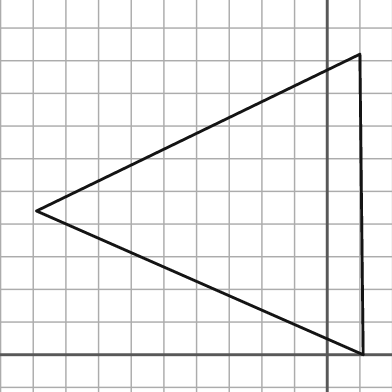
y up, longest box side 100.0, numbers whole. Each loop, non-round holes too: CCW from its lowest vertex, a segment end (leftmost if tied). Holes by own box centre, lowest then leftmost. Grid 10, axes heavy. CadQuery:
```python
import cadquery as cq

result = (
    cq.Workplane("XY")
    .moveTo(11.0, 0.0)
    .lineTo(10.0, 92.0)
    .lineTo(-89.0, 44.0)
    .close()
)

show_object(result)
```